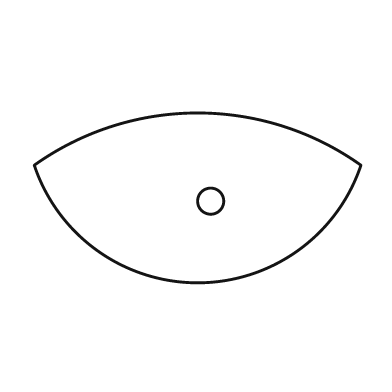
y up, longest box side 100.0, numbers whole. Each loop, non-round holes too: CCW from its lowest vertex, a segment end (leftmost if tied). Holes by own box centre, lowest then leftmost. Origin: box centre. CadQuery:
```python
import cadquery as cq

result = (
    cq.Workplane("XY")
    .moveTo(-50.0, 10.0)
    .threePointArc((0.0, -26.0), (50.0, 10.0))
    .threePointArc((0.0, 26.0), (-50.0, 10.0))
    .close()
    .moveTo(4.0, -1.0)
    .circle(4.0)
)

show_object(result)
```